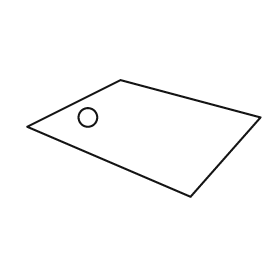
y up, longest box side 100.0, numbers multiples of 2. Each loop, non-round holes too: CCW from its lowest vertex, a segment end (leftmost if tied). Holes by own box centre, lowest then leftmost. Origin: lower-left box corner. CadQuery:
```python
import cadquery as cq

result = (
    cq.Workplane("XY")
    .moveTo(70.0, 0.0)
    .lineTo(100.0, 34.0)
    .lineTo(40.0, 50.0)
    .lineTo(0.0, 30.0)
    .close()
    .moveTo(26.0, 34.0)
    .circle(4.0)
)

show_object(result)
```